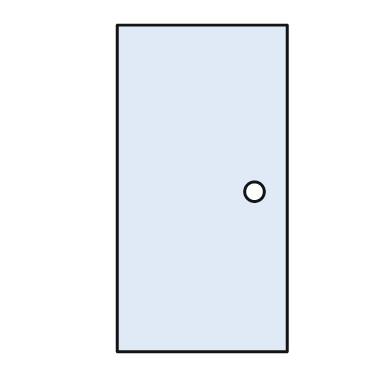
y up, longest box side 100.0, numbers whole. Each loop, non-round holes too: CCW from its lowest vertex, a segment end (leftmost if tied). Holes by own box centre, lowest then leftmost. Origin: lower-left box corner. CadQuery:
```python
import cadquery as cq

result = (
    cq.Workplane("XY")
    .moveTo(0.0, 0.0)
    .lineTo(52.0, 0.0)
    .lineTo(52.0, 100.0)
    .lineTo(0.0, 100.0)
    .close()
    .moveTo(42.0, 49.0)
    .circle(3.0)
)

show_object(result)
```